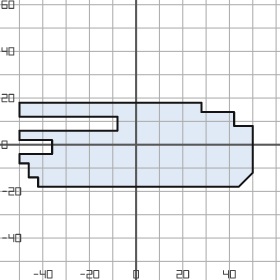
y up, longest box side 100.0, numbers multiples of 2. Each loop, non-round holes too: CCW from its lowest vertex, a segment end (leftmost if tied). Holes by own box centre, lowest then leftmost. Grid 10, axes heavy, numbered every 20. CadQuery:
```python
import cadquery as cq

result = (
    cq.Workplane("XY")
    .moveTo(-42.0, -18.0)
    .lineTo(44.0, -18.0)
    .lineTo(50.0, -12.0)
    .lineTo(50.0, 8.0)
    .lineTo(42.0, 8.0)
    .lineTo(42.0, 14.0)
    .lineTo(28.0, 14.0)
    .lineTo(28.0, 18.0)
    .lineTo(-50.0, 18.0)
    .lineTo(-50.0, 12.0)
    .lineTo(-8.0, 12.0)
    .lineTo(-8.0, 6.0)
    .lineTo(-50.0, 6.0)
    .lineTo(-50.0, 2.0)
    .lineTo(-36.0, 2.0)
    .lineTo(-36.0, -4.0)
    .lineTo(-50.0, -4.0)
    .lineTo(-50.0, -8.0)
    .lineTo(-46.0, -8.0)
    .lineTo(-46.0, -14.0)
    .lineTo(-42.0, -14.0)
    .close()
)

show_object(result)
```